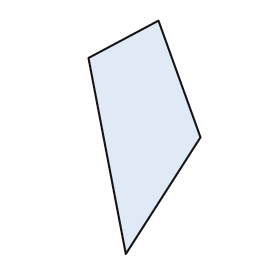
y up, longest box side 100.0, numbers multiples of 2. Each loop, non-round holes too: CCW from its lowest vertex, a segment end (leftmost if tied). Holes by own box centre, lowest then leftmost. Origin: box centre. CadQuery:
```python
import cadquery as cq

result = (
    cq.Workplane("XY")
    .moveTo(-8.0, -50.0)
    .lineTo(24.0, 0.0)
    .lineTo(6.0, 50.0)
    .lineTo(-24.0, 34.0)
    .close()
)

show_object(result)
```